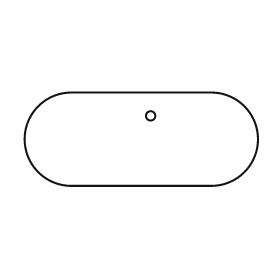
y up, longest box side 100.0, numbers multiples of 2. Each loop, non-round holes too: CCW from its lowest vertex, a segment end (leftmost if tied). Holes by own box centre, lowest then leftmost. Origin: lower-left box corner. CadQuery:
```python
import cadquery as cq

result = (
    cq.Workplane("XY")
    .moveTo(20.0, 0.0)
    .lineTo(80.0, 0.0)
    .threePointArc((100.0, 20.0), (80.0, 40.0))
    .lineTo(20.0, 40.0)
    .threePointArc((0.0, 20.0), (20.0, 0.0))
    .close()
    .moveTo(54.0, 30.0)
    .circle(2.0)
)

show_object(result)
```